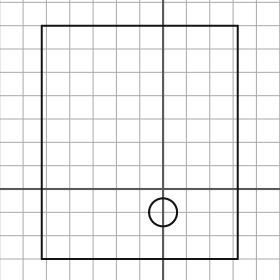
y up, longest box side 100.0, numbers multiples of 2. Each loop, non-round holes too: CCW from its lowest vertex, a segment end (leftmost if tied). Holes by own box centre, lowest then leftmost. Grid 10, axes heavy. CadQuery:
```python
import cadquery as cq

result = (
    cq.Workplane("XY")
    .moveTo(-52.0, -30.0)
    .lineTo(32.0, -30.0)
    .lineTo(32.0, 70.0)
    .lineTo(-52.0, 70.0)
    .close()
    .moveTo(0.0, -10.0)
    .circle(6.0)
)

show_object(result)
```